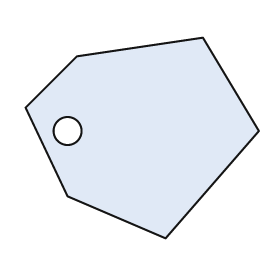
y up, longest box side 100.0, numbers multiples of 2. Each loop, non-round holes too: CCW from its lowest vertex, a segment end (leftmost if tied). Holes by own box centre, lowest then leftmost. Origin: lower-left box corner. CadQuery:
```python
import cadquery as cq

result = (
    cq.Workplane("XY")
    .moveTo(60.0, 0.0)
    .lineTo(100.0, 46.0)
    .lineTo(76.0, 86.0)
    .lineTo(22.0, 78.0)
    .lineTo(0.0, 56.0)
    .lineTo(18.0, 18.0)
    .close()
    .moveTo(18.0, 46.0)
    .circle(6.0)
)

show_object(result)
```